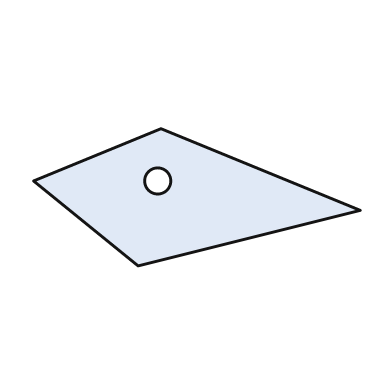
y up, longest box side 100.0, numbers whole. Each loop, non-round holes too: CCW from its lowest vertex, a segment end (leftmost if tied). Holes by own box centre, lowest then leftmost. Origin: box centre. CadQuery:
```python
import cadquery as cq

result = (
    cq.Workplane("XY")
    .moveTo(-18.0, -21.0)
    .lineTo(50.0, -4.0)
    .lineTo(-11.0, 21.0)
    .lineTo(-50.0, 5.0)
    .close()
    .moveTo(-12.0, 5.0)
    .circle(4.0)
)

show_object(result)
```